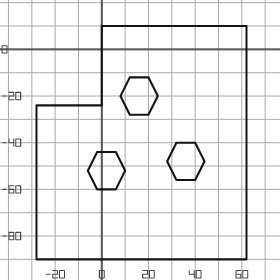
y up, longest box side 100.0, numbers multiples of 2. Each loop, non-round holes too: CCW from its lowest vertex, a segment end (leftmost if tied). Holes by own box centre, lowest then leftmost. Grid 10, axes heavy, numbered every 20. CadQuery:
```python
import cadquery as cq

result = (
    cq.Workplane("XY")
    .moveTo(-28.0, -90.0)
    .lineTo(62.0, -90.0)
    .lineTo(62.0, 10.0)
    .lineTo(0.0, 10.0)
    .lineTo(0.0, -24.0)
    .lineTo(-28.0, -24.0)
    .close()
    .moveTo(-2.0, -60.0)
    .lineTo(6.0, -60.0)
    .lineTo(10.0, -52.0)
    .lineTo(6.0, -44.0)
    .lineTo(-2.0, -44.0)
    .lineTo(-6.0, -52.0)
    .close()
    .moveTo(32.0, -56.0)
    .lineTo(40.0, -56.0)
    .lineTo(44.0, -48.0)
    .lineTo(40.0, -40.0)
    .lineTo(32.0, -40.0)
    .lineTo(28.0, -48.0)
    .close()
    .moveTo(12.0, -28.0)
    .lineTo(20.0, -28.0)
    .lineTo(24.0, -20.0)
    .lineTo(20.0, -12.0)
    .lineTo(12.0, -12.0)
    .lineTo(8.0, -20.0)
    .close()
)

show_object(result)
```